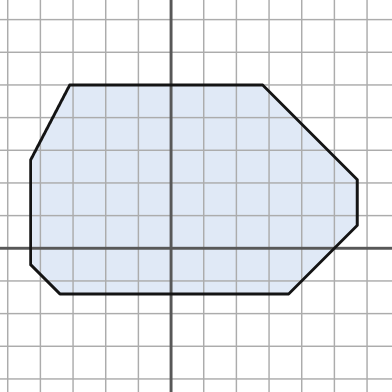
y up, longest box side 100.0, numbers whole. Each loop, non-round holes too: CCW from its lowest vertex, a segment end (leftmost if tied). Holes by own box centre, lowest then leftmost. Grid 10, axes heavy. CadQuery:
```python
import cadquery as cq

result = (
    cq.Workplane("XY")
    .moveTo(-34.0, -14.0)
    .lineTo(36.0, -14.0)
    .lineTo(57.0, 7.0)
    .lineTo(57.0, 21.0)
    .lineTo(28.0, 50.0)
    .lineTo(-31.0, 50.0)
    .lineTo(-43.0, 27.0)
    .lineTo(-43.0, -5.0)
    .close()
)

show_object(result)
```